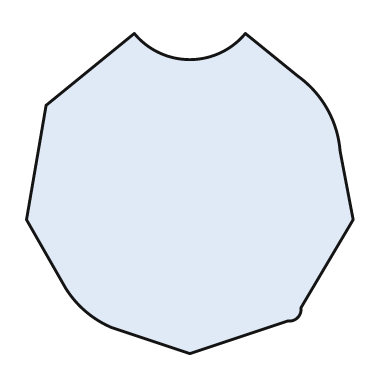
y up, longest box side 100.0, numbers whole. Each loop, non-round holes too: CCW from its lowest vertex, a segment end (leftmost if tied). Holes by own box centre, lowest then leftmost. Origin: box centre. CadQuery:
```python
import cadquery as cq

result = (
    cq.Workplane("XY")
    .moveTo(0.0, -49.0)
    .lineTo(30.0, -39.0)
    .threePointArc((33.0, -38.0), (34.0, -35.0))
    .lineTo(50.0, -8.0)
    .lineTo(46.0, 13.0)
    .threePointArc((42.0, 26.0), (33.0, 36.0))
    .lineTo(17.0, 49.0)
    .threePointArc((0.0, 41.0), (-17.0, 49.0))
    .lineTo(-44.0, 27.0)
    .lineTo(-50.0, -8.0)
    .lineTo(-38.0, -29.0)
    .threePointArc((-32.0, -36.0), (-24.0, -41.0))
    .close()
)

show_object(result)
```